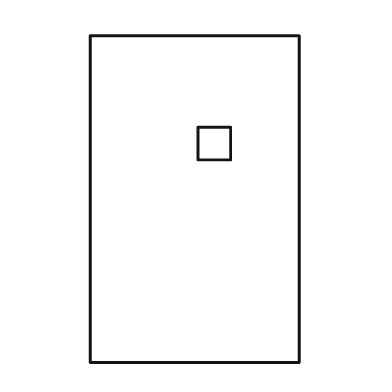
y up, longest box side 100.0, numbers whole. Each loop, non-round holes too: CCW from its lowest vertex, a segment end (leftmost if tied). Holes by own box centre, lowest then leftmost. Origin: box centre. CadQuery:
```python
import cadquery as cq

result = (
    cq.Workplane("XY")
    .moveTo(-32.0, -50.0)
    .lineTo(32.0, -50.0)
    .lineTo(32.0, 50.0)
    .lineTo(-32.0, 50.0)
    .close()
    .moveTo(1.0, 12.0)
    .lineTo(11.0, 12.0)
    .lineTo(11.0, 22.0)
    .lineTo(1.0, 22.0)
    .close()
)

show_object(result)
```